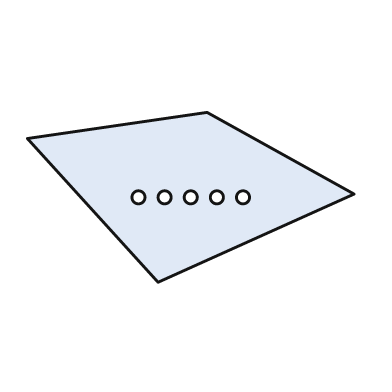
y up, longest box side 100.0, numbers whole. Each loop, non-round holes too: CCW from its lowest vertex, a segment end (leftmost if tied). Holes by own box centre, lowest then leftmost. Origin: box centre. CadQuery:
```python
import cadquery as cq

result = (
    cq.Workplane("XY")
    .moveTo(-10.0, -26.0)
    .lineTo(50.0, 1.0)
    .lineTo(5.0, 26.0)
    .lineTo(-50.0, 18.0)
    .close()
    .moveTo(-16.0, 0.0)
    .circle(2.0)
    .moveTo(-8.0, 0.0)
    .circle(2.0)
    .moveTo(0.0, 0.0)
    .circle(2.0)
    .moveTo(8.0, 0.0)
    .circle(2.0)
    .moveTo(16.0, 0.0)
    .circle(2.0)
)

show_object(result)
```